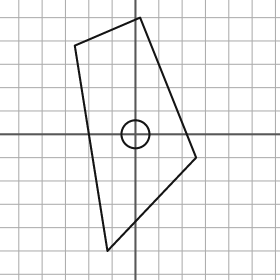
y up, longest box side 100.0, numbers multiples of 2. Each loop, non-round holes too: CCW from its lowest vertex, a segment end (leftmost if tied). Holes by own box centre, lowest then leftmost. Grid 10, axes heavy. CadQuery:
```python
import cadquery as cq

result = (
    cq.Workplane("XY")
    .moveTo(-12.0, -50.0)
    .lineTo(26.0, -10.0)
    .lineTo(2.0, 50.0)
    .lineTo(-26.0, 38.0)
    .close()
    .moveTo(0.0, 0.0)
    .circle(6.0)
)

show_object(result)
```